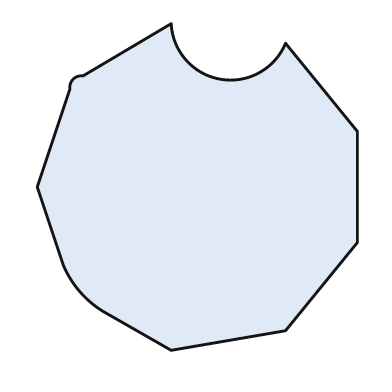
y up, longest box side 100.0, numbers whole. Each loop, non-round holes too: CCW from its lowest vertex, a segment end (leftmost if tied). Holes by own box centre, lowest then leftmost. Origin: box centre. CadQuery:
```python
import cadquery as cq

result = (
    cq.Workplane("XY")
    .moveTo(-8.0, -50.0)
    .lineTo(27.0, -44.0)
    .lineTo(49.0, -17.0)
    .lineTo(49.0, 17.0)
    .lineTo(27.0, 44.0)
    .threePointArc((7.0, 33.0), (-8.0, 50.0))
    .lineTo(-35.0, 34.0)
    .threePointArc((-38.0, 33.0), (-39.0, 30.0))
    .lineTo(-49.0, 0.0)
    .lineTo(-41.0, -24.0)
    .threePointArc((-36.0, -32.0), (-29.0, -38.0))
    .close()
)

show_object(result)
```